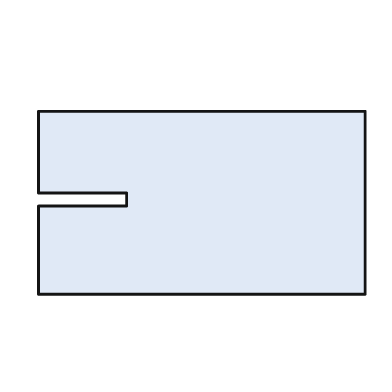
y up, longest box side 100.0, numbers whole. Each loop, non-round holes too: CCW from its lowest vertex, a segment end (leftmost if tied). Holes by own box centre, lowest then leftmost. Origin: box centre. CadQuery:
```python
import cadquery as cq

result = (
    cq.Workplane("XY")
    .moveTo(-50.0, -28.0)
    .lineTo(50.0, -28.0)
    .lineTo(50.0, 28.0)
    .lineTo(-50.0, 28.0)
    .lineTo(-50.0, 3.0)
    .lineTo(-23.0, 3.0)
    .lineTo(-23.0, -1.0)
    .lineTo(-50.0, -1.0)
    .close()
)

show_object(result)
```